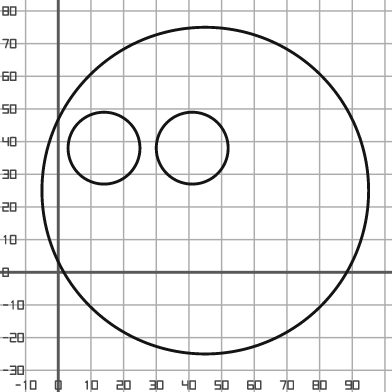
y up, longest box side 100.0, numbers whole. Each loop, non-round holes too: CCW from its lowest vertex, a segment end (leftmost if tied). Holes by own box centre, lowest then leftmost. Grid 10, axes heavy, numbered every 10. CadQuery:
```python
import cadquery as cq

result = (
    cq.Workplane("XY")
    .moveTo(45.0, 25.0)
    .circle(50.0)
    .moveTo(14.0, 38.0)
    .circle(11.0)
    .moveTo(41.0, 38.0)
    .circle(11.0)
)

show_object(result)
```